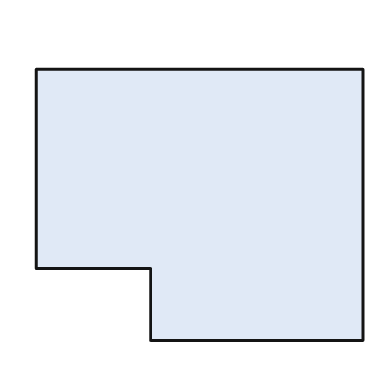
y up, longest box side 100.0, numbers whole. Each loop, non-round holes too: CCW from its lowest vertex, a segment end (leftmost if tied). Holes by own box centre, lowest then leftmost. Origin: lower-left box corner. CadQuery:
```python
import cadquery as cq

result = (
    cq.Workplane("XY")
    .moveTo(35.0, 0.0)
    .lineTo(100.0, 0.0)
    .lineTo(100.0, 83.0)
    .lineTo(0.0, 83.0)
    .lineTo(0.0, 22.0)
    .lineTo(35.0, 22.0)
    .close()
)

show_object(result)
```